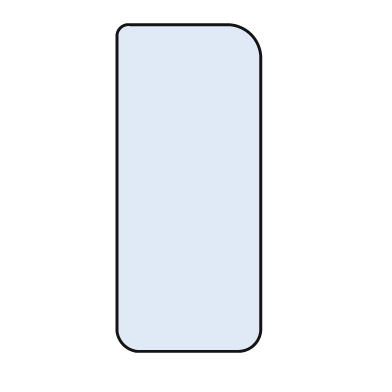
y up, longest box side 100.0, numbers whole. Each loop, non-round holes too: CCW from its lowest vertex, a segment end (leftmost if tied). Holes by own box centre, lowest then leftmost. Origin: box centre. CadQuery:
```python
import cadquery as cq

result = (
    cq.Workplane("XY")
    .moveTo(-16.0, -50.0)
    .lineTo(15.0, -50.0)
    .threePointArc((20.0, -48.0), (22.0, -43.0))
    .lineTo(22.0, 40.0)
    .threePointArc((19.0, 47.0), (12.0, 50.0))
    .lineTo(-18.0, 50.0)
    .threePointArc((-21.0, 49.0), (-22.0, 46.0))
    .lineTo(-22.0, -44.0)
    .threePointArc((-20.0, -48.0), (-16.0, -50.0))
    .close()
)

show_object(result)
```